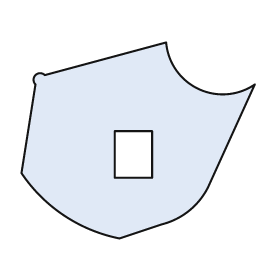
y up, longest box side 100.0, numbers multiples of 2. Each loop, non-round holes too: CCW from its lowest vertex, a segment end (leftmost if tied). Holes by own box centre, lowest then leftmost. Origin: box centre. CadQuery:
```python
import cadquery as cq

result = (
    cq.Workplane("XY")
    .moveTo(-8.0, -42.0)
    .lineTo(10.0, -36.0)
    .threePointArc((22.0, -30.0), (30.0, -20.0))
    .lineTo(50.0, 24.0)
    .threePointArc((26.0, 22.0), (12.0, 42.0))
    .lineTo(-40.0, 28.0)
    .threePointArc((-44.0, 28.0), (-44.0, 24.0))
    .lineTo(-50.0, -14.0)
    .threePointArc((-32.0, -32.0), (-8.0, -42.0))
    .close()
    .moveTo(-10.0, -16.0)
    .lineTo(6.0, -16.0)
    .lineTo(6.0, 4.0)
    .lineTo(-10.0, 4.0)
    .close()
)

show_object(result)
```